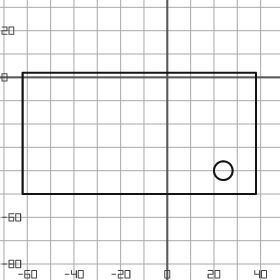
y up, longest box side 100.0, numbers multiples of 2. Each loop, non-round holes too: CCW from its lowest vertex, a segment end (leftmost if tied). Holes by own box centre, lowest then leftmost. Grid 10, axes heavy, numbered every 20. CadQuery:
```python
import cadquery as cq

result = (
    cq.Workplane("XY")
    .moveTo(-62.0, -50.0)
    .lineTo(38.0, -50.0)
    .lineTo(38.0, 2.0)
    .lineTo(-62.0, 2.0)
    .close()
    .moveTo(24.0, -40.0)
    .circle(4.0)
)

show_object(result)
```